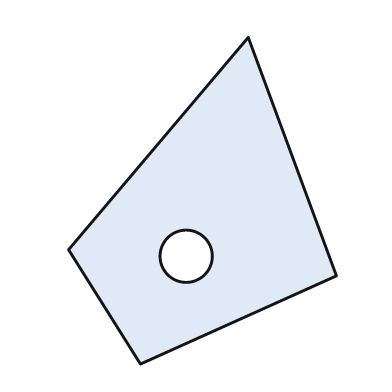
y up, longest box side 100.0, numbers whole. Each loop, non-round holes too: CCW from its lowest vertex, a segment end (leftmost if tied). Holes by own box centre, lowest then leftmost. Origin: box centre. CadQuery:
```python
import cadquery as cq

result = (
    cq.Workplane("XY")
    .moveTo(-19.0, -50.0)
    .lineTo(41.0, -23.0)
    .lineTo(14.0, 50.0)
    .lineTo(-41.0, -15.0)
    .close()
    .moveTo(-5.0, -17.0)
    .circle(8.0)
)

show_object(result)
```